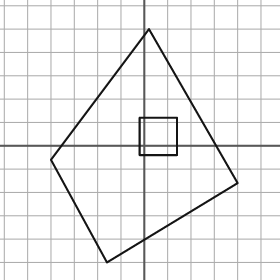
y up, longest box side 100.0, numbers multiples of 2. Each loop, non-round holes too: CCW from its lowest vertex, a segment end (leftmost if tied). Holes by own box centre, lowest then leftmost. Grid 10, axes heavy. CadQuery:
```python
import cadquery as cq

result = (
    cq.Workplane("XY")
    .moveTo(-16.0, -50.0)
    .lineTo(40.0, -16.0)
    .lineTo(2.0, 50.0)
    .lineTo(-40.0, -6.0)
    .close()
    .moveTo(-2.0, -4.0)
    .lineTo(14.0, -4.0)
    .lineTo(14.0, 12.0)
    .lineTo(-2.0, 12.0)
    .close()
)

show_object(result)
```